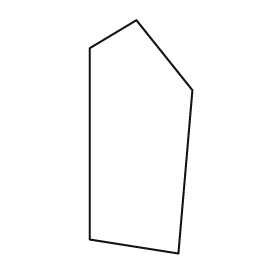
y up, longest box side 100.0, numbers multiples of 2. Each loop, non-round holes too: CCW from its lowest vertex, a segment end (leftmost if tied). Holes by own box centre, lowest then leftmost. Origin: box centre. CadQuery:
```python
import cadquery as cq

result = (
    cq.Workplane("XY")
    .moveTo(16.0, -50.0)
    .lineTo(22.0, 20.0)
    .lineTo(-2.0, 50.0)
    .lineTo(-22.0, 38.0)
    .lineTo(-22.0, -44.0)
    .close()
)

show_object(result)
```